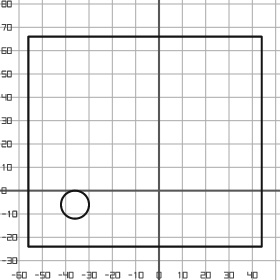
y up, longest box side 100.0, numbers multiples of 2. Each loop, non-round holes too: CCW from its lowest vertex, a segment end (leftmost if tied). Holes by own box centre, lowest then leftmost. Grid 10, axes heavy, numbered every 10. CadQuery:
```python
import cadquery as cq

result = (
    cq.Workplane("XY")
    .moveTo(-56.0, -24.0)
    .lineTo(44.0, -24.0)
    .lineTo(44.0, 66.0)
    .lineTo(-56.0, 66.0)
    .close()
    .moveTo(-36.0, -6.0)
    .circle(6.0)
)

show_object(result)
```